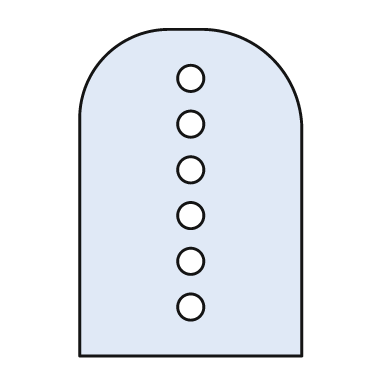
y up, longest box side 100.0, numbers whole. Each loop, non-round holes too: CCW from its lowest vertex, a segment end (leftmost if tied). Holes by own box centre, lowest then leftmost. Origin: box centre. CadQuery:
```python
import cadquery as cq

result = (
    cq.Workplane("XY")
    .moveTo(-34.0, -50.0)
    .lineTo(34.0, -50.0)
    .lineTo(34.0, 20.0)
    .threePointArc((25.0, 41.0), (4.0, 50.0))
    .lineTo(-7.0, 50.0)
    .threePointArc((-26.0, 42.0), (-34.0, 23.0))
    .close()
    .moveTo(0.0, -35.0)
    .circle(4.0)
    .moveTo(0.0, -21.0)
    .circle(4.0)
    .moveTo(0.0, -7.0)
    .circle(4.0)
    .moveTo(0.0, 7.0)
    .circle(4.0)
    .moveTo(0.0, 21.0)
    .circle(4.0)
    .moveTo(0.0, 35.0)
    .circle(4.0)
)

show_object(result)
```